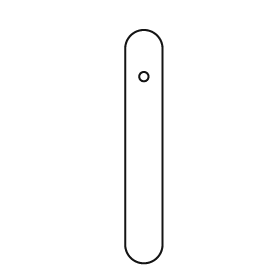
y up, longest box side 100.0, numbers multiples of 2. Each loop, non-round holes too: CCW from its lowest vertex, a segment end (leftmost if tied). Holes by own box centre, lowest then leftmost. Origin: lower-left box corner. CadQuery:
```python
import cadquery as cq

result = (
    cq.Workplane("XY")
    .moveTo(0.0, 8.0)
    .threePointArc((8.0, 0.0), (16.0, 8.0))
    .lineTo(16.0, 92.0)
    .threePointArc((8.0, 100.0), (0.0, 92.0))
    .close()
    .moveTo(8.0, 80.0)
    .circle(2.0)
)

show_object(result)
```